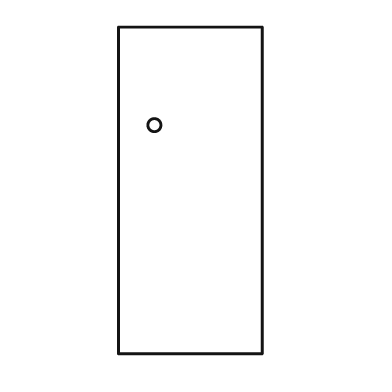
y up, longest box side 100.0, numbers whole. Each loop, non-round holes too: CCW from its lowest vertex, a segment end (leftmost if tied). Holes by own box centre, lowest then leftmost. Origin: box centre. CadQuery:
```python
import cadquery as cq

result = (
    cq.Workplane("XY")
    .moveTo(-22.0, -50.0)
    .lineTo(22.0, -50.0)
    .lineTo(22.0, 50.0)
    .lineTo(-22.0, 50.0)
    .close()
    .moveTo(-11.0, 20.0)
    .circle(2.0)
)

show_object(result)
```